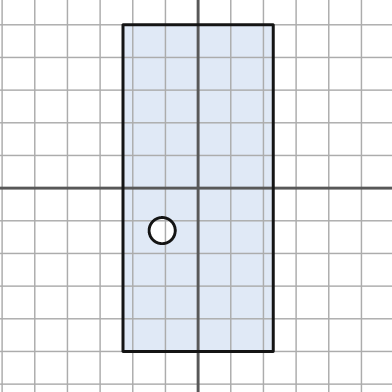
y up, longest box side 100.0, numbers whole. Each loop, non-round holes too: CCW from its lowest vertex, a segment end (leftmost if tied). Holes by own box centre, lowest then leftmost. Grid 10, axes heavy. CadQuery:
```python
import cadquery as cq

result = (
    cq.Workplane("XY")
    .moveTo(-23.0, -50.0)
    .lineTo(23.0, -50.0)
    .lineTo(23.0, 50.0)
    .lineTo(-23.0, 50.0)
    .close()
    .moveTo(-11.0, -13.0)
    .circle(4.0)
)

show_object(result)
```